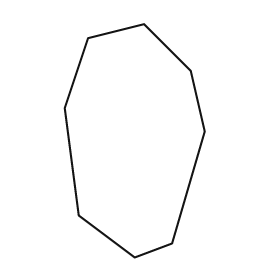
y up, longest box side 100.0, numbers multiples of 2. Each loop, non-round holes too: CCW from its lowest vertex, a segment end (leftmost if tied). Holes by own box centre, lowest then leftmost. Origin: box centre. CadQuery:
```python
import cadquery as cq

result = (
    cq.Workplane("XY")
    .moveTo(0.0, -50.0)
    .lineTo(16.0, -44.0)
    .lineTo(30.0, 4.0)
    .lineTo(24.0, 30.0)
    .lineTo(4.0, 50.0)
    .lineTo(-20.0, 44.0)
    .lineTo(-30.0, 14.0)
    .lineTo(-24.0, -32.0)
    .close()
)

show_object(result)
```